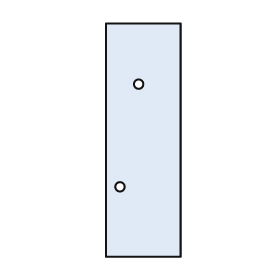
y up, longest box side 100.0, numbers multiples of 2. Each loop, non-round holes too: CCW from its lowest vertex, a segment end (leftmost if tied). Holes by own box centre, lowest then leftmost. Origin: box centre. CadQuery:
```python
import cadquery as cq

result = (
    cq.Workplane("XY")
    .moveTo(-16.0, -50.0)
    .lineTo(16.0, -50.0)
    .lineTo(16.0, 50.0)
    .lineTo(-16.0, 50.0)
    .close()
    .moveTo(-10.0, -20.0)
    .circle(2.0)
    .moveTo(-2.0, 24.0)
    .circle(2.0)
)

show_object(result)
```